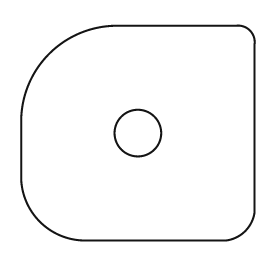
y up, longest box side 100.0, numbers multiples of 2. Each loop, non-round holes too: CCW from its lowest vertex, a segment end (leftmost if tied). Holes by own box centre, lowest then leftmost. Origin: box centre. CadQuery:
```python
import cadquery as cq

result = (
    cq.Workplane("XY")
    .moveTo(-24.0, -46.0)
    .lineTo(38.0, -46.0)
    .threePointArc((46.0, -42.0), (50.0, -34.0))
    .lineTo(50.0, 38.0)
    .threePointArc((48.0, 44.0), (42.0, 46.0))
    .lineTo(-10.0, 46.0)
    .threePointArc((-38.0, 34.0), (-50.0, 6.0))
    .lineTo(-50.0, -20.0)
    .threePointArc((-42.0, -38.0), (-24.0, -46.0))
    .close()
    .moveTo(0.0, 0.0)
    .circle(10.0)
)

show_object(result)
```